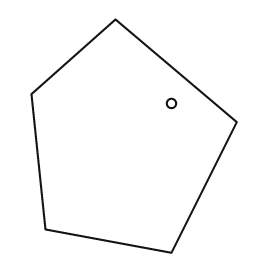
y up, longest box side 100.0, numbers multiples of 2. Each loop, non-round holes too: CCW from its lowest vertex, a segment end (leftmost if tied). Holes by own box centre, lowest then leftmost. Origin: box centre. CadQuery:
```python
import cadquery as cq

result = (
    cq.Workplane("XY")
    .moveTo(16.0, -50.0)
    .lineTo(44.0, 6.0)
    .lineTo(-8.0, 50.0)
    .lineTo(-44.0, 18.0)
    .lineTo(-38.0, -40.0)
    .close()
    .moveTo(16.0, 14.0)
    .circle(2.0)
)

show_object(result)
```